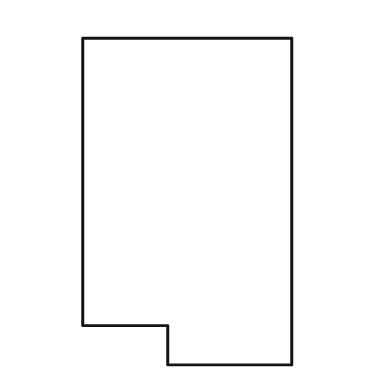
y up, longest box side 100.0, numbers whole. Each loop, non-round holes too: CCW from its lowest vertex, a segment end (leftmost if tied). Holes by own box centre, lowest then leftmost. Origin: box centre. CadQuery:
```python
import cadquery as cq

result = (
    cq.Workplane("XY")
    .moveTo(-6.0, -50.0)
    .lineTo(32.0, -50.0)
    .lineTo(32.0, 50.0)
    .lineTo(-32.0, 50.0)
    .lineTo(-32.0, -38.0)
    .lineTo(-6.0, -38.0)
    .close()
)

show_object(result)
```